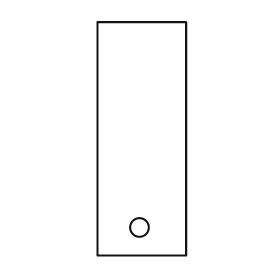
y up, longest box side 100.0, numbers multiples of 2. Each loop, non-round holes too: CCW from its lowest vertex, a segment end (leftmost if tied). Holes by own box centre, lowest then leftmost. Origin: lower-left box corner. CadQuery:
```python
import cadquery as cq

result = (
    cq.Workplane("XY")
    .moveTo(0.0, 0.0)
    .lineTo(38.0, 0.0)
    .lineTo(38.0, 100.0)
    .lineTo(0.0, 100.0)
    .close()
    .moveTo(18.0, 12.0)
    .circle(4.0)
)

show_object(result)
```